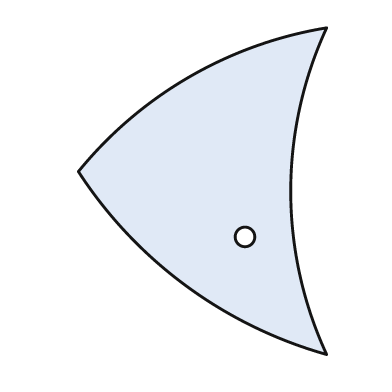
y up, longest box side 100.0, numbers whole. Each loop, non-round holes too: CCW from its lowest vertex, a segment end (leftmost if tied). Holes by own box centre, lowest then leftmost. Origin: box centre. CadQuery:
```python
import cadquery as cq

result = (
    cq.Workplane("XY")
    .moveTo(38.0, -50.0)
    .threePointArc((27.0, 0.0), (38.0, 50.0))
    .threePointArc((-4.0, 35.0), (-38.0, 6.0))
    .threePointArc((-5.0, -29.0), (38.0, -50.0))
    .close()
    .moveTo(13.0, -14.0)
    .circle(3.0)
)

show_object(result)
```